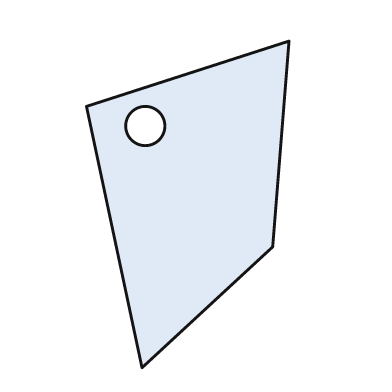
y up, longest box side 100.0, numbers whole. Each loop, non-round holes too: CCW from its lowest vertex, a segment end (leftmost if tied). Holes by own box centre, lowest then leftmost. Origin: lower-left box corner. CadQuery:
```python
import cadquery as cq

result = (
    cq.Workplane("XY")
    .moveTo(17.0, 0.0)
    .lineTo(57.0, 37.0)
    .lineTo(62.0, 100.0)
    .lineTo(0.0, 80.0)
    .close()
    .moveTo(18.0, 74.0)
    .circle(6.0)
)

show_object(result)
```